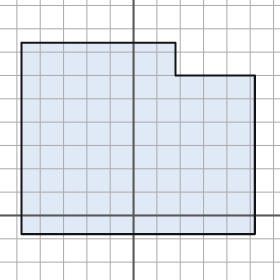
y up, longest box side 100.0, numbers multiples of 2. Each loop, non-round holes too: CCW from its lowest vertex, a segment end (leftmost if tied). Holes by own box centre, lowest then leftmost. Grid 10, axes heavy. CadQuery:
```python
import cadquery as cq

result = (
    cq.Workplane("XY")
    .moveTo(-48.0, -8.0)
    .lineTo(52.0, -8.0)
    .lineTo(52.0, 60.0)
    .lineTo(18.0, 60.0)
    .lineTo(18.0, 74.0)
    .lineTo(-48.0, 74.0)
    .close()
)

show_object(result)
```